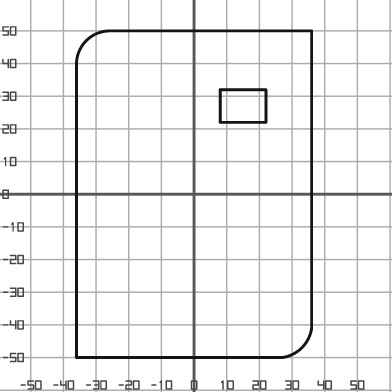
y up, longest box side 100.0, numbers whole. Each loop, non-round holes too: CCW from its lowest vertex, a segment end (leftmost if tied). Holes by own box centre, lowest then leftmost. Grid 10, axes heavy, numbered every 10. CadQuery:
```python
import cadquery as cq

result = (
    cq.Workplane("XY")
    .moveTo(-36.0, -50.0)
    .lineTo(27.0, -50.0)
    .threePointArc((33.0, -47.0), (36.0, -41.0))
    .lineTo(36.0, 50.0)
    .lineTo(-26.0, 50.0)
    .threePointArc((-33.0, 47.0), (-36.0, 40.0))
    .close()
    .moveTo(8.0, 22.0)
    .lineTo(22.0, 22.0)
    .lineTo(22.0, 32.0)
    .lineTo(8.0, 32.0)
    .close()
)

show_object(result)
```